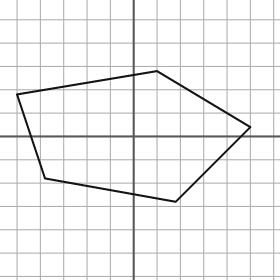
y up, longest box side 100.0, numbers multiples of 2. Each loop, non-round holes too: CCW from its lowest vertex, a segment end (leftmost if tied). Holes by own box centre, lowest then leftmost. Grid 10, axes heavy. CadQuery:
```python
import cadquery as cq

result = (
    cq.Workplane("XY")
    .moveTo(18.0, -28.0)
    .lineTo(50.0, 4.0)
    .lineTo(10.0, 28.0)
    .lineTo(-50.0, 18.0)
    .lineTo(-38.0, -18.0)
    .close()
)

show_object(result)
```